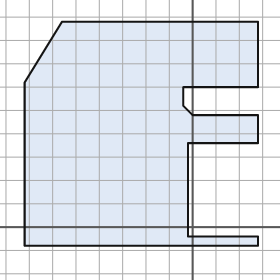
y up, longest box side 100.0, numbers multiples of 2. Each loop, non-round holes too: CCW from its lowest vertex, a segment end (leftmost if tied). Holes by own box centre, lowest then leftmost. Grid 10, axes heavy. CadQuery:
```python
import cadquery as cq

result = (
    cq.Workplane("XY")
    .moveTo(-72.0, -8.0)
    .lineTo(28.0, -8.0)
    .lineTo(28.0, -4.0)
    .lineTo(-2.0, -4.0)
    .lineTo(-2.0, 36.0)
    .lineTo(28.0, 36.0)
    .lineTo(28.0, 48.0)
    .lineTo(0.0, 48.0)
    .lineTo(-4.0, 52.0)
    .lineTo(-4.0, 60.0)
    .lineTo(28.0, 60.0)
    .lineTo(28.0, 88.0)
    .lineTo(-56.0, 88.0)
    .lineTo(-72.0, 62.0)
    .close()
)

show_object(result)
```